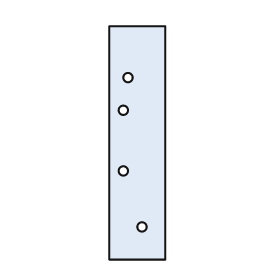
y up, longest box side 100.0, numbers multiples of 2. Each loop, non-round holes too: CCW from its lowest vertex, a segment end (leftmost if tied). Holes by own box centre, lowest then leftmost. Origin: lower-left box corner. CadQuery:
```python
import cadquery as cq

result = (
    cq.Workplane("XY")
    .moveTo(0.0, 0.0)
    .lineTo(24.0, 0.0)
    .lineTo(24.0, 100.0)
    .lineTo(0.0, 100.0)
    .close()
    .moveTo(14.0, 14.0)
    .circle(2.0)
    .moveTo(6.0, 38.0)
    .circle(2.0)
    .moveTo(6.0, 64.0)
    .circle(2.0)
    .moveTo(8.0, 78.0)
    .circle(2.0)
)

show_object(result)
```